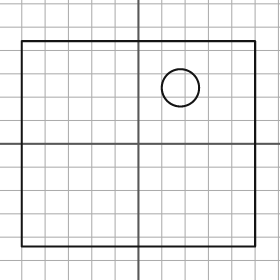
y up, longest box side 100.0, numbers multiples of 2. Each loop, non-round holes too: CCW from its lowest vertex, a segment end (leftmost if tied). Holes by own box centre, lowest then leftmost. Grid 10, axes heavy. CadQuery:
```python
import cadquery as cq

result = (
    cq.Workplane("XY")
    .moveTo(-50.0, -44.0)
    .lineTo(50.0, -44.0)
    .lineTo(50.0, 44.0)
    .lineTo(-50.0, 44.0)
    .close()
    .moveTo(18.0, 24.0)
    .circle(8.0)
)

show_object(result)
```